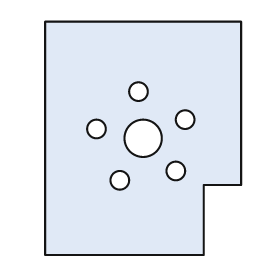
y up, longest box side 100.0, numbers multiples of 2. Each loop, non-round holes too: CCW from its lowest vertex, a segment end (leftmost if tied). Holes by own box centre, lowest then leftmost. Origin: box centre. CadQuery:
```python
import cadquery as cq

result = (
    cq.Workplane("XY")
    .moveTo(-42.0, -50.0)
    .lineTo(26.0, -50.0)
    .lineTo(26.0, -20.0)
    .lineTo(42.0, -20.0)
    .lineTo(42.0, 50.0)
    .lineTo(-42.0, 50.0)
    .close()
    .moveTo(-10.0, -18.0)
    .circle(4.0)
    .moveTo(14.0, -14.0)
    .circle(4.0)
    .moveTo(0.0, 0.0)
    .circle(8.0)
    .moveTo(-20.0, 4.0)
    .circle(4.0)
    .moveTo(18.0, 8.0)
    .circle(4.0)
    .moveTo(-2.0, 20.0)
    .circle(4.0)
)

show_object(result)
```